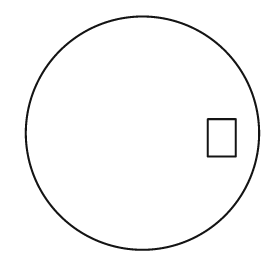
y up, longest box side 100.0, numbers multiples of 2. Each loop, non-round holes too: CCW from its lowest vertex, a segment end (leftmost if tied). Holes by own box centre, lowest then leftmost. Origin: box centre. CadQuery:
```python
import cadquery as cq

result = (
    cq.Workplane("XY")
    .moveTo(0.0, 0.0)
    .circle(50.0)
    .moveTo(28.0, -10.0)
    .lineTo(40.0, -10.0)
    .lineTo(40.0, 6.0)
    .lineTo(28.0, 6.0)
    .close()
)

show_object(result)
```